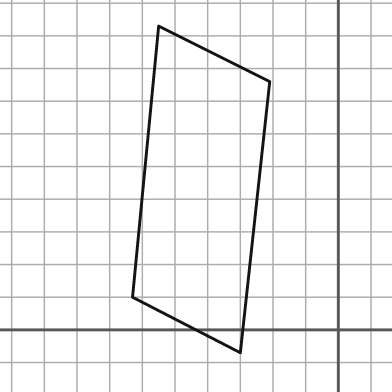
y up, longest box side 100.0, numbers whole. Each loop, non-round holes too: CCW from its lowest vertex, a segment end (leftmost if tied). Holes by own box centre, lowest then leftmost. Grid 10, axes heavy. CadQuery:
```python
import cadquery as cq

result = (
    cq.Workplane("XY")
    .moveTo(-30.0, -7.0)
    .lineTo(-21.0, 76.0)
    .lineTo(-55.0, 93.0)
    .lineTo(-63.0, 10.0)
    .close()
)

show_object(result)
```